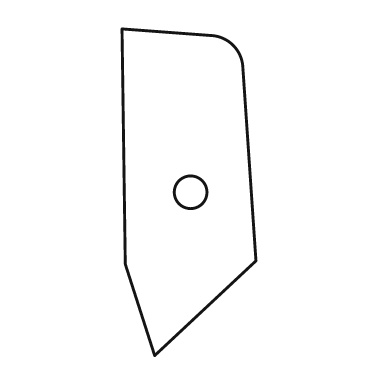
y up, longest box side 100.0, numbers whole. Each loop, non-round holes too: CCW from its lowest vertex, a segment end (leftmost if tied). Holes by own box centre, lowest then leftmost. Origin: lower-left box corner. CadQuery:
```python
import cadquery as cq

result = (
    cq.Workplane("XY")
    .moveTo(10.0, 0.0)
    .lineTo(41.0, 29.0)
    .lineTo(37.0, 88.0)
    .threePointArc((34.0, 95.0), (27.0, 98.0))
    .lineTo(0.0, 100.0)
    .lineTo(1.0, 28.0)
    .close()
    .moveTo(21.0, 50.0)
    .circle(5.0)
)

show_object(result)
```